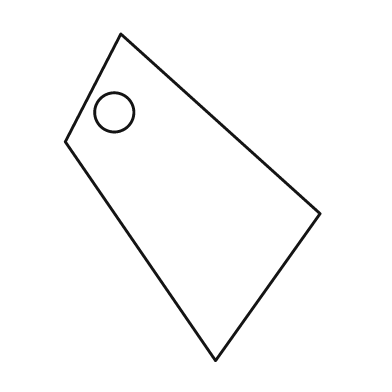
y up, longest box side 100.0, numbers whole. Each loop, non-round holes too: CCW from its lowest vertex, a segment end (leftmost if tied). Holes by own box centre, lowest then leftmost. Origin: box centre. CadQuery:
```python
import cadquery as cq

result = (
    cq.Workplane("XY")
    .moveTo(7.0, -50.0)
    .lineTo(39.0, -5.0)
    .lineTo(-22.0, 50.0)
    .lineTo(-39.0, 17.0)
    .close()
    .moveTo(-24.0, 26.0)
    .circle(6.0)
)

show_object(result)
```